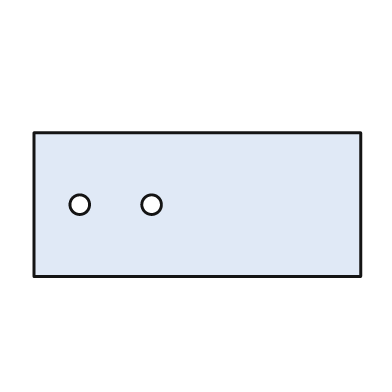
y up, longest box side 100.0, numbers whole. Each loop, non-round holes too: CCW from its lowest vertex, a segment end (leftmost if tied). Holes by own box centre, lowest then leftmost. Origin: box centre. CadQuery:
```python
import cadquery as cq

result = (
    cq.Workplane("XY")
    .moveTo(-50.0, -22.0)
    .lineTo(50.0, -22.0)
    .lineTo(50.0, 22.0)
    .lineTo(-50.0, 22.0)
    .close()
    .moveTo(-36.0, 0.0)
    .circle(3.0)
    .moveTo(-14.0, 0.0)
    .circle(3.0)
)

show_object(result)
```